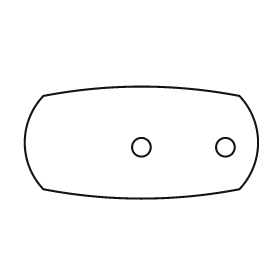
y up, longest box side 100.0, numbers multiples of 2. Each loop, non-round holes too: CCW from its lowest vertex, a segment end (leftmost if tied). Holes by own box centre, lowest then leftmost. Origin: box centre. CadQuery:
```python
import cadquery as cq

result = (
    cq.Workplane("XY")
    .moveTo(-42.0, -20.0)
    .threePointArc((0.0, -24.0), (42.0, -20.0))
    .threePointArc((50.0, 0.0), (42.0, 20.0))
    .threePointArc((0.0, 24.0), (-42.0, 20.0))
    .threePointArc((-50.0, 0.0), (-42.0, -20.0))
    .close()
    .moveTo(0.0, -2.0)
    .circle(4.0)
    .moveTo(36.0, -2.0)
    .circle(4.0)
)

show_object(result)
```